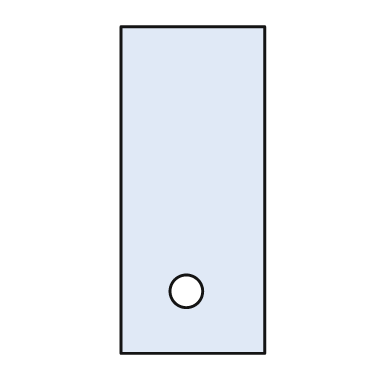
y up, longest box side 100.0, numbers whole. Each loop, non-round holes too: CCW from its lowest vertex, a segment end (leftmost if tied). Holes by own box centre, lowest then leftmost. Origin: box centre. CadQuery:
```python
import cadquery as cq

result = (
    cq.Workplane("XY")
    .moveTo(-22.0, -50.0)
    .lineTo(22.0, -50.0)
    .lineTo(22.0, 50.0)
    .lineTo(-22.0, 50.0)
    .close()
    .moveTo(-2.0, -31.0)
    .circle(5.0)
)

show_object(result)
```